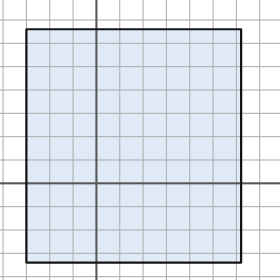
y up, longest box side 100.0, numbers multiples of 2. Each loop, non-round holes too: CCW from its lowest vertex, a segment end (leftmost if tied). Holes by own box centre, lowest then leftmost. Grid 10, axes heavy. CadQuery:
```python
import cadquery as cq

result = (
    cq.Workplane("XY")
    .moveTo(-30.0, -34.0)
    .lineTo(62.0, -34.0)
    .lineTo(62.0, 66.0)
    .lineTo(-30.0, 66.0)
    .close()
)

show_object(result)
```